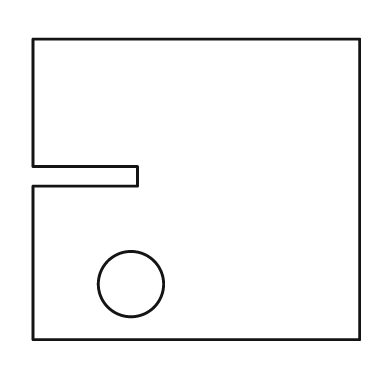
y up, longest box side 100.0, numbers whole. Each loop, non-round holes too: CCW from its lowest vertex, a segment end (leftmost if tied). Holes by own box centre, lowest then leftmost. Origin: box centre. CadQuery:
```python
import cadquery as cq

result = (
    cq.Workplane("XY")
    .moveTo(-50.0, -46.0)
    .lineTo(50.0, -46.0)
    .lineTo(50.0, 46.0)
    .lineTo(-50.0, 46.0)
    .lineTo(-50.0, 7.0)
    .lineTo(-18.0, 7.0)
    .lineTo(-18.0, 1.0)
    .lineTo(-50.0, 1.0)
    .close()
    .moveTo(-20.0, -29.0)
    .circle(10.0)
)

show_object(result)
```